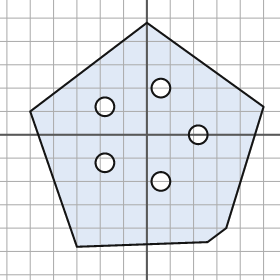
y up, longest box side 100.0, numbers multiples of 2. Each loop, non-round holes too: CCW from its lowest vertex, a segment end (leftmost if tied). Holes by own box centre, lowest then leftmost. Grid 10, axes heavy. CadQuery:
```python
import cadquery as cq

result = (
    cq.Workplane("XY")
    .moveTo(-30.0, -48.0)
    .lineTo(26.0, -46.0)
    .lineTo(34.0, -40.0)
    .lineTo(50.0, 12.0)
    .lineTo(0.0, 48.0)
    .lineTo(-50.0, 10.0)
    .close()
    .moveTo(6.0, -20.0)
    .circle(4.0)
    .moveTo(-18.0, -12.0)
    .circle(4.0)
    .moveTo(22.0, 0.0)
    .circle(4.0)
    .moveTo(-18.0, 12.0)
    .circle(4.0)
    .moveTo(6.0, 20.0)
    .circle(4.0)
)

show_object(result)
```